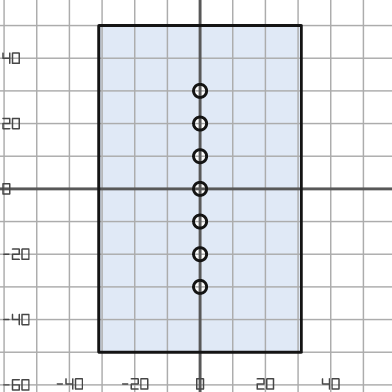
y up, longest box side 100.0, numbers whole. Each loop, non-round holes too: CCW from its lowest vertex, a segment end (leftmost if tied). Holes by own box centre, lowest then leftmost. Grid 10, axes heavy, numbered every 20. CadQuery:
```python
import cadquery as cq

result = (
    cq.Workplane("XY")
    .moveTo(-31.0, -50.0)
    .lineTo(31.0, -50.0)
    .lineTo(31.0, 50.0)
    .lineTo(-31.0, 50.0)
    .close()
    .moveTo(0.0, -30.0)
    .circle(2.0)
    .moveTo(0.0, -20.0)
    .circle(2.0)
    .moveTo(0.0, -10.0)
    .circle(2.0)
    .moveTo(0.0, 0.0)
    .circle(2.0)
    .moveTo(0.0, 10.0)
    .circle(2.0)
    .moveTo(0.0, 20.0)
    .circle(2.0)
    .moveTo(0.0, 30.0)
    .circle(2.0)
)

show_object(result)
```